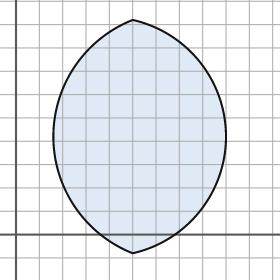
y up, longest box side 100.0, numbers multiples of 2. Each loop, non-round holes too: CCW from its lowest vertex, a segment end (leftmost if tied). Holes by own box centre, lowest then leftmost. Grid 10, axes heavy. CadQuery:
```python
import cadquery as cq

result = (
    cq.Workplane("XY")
    .moveTo(50.0, -8.0)
    .threePointArc((90.0, 42.0), (50.0, 92.0))
    .threePointArc((16.0, 42.0), (50.0, -8.0))
    .close()
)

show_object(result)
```